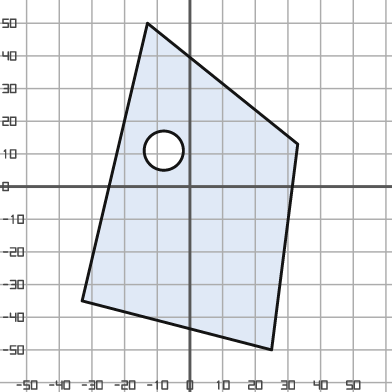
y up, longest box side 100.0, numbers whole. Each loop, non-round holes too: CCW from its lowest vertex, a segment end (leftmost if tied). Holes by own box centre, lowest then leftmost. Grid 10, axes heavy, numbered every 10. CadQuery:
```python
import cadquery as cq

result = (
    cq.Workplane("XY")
    .moveTo(25.0, -50.0)
    .lineTo(33.0, 13.0)
    .lineTo(-13.0, 50.0)
    .lineTo(-33.0, -35.0)
    .close()
    .moveTo(-8.0, 11.0)
    .circle(6.0)
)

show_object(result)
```